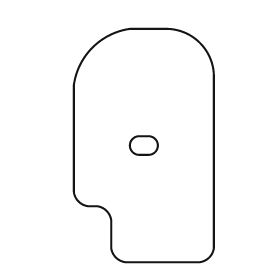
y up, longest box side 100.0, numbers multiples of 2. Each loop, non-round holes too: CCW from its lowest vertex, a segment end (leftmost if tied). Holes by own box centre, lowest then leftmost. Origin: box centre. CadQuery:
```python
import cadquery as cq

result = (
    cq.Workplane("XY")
    .moveTo(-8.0, -50.0)
    .lineTo(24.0, -50.0)
    .threePointArc((28.0, -48.0), (30.0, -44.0))
    .lineTo(30.0, 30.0)
    .threePointArc((24.0, 44.0), (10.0, 50.0))
    .lineTo(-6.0, 50.0)
    .threePointArc((-22.0, 42.0), (-30.0, 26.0))
    .lineTo(-30.0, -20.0)
    .threePointArc((-28.0, -24.0), (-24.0, -26.0))
    .lineTo(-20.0, -26.0)
    .threePointArc((-16.0, -28.0), (-14.0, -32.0))
    .lineTo(-14.0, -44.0)
    .threePointArc((-12.0, -48.0), (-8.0, -50.0))
    .close()
    .moveTo(-2.0, -4.0)
    .lineTo(2.0, -4.0)
    .threePointArc((6.0, 0.0), (2.0, 4.0))
    .lineTo(-2.0, 4.0)
    .threePointArc((-6.0, 0.0), (-2.0, -4.0))
    .close()
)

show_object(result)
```